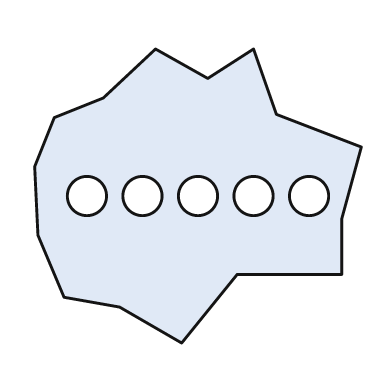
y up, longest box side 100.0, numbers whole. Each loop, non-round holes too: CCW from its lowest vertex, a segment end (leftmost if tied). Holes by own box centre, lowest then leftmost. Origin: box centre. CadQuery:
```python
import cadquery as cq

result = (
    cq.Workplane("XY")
    .moveTo(-5.0, -45.0)
    .lineTo(12.0, -24.0)
    .lineTo(44.0, -24.0)
    .lineTo(44.0, -7.0)
    .lineTo(50.0, 15.0)
    .lineTo(24.0, 25.0)
    .lineTo(17.0, 45.0)
    .lineTo(3.0, 36.0)
    .lineTo(-13.0, 45.0)
    .lineTo(-29.0, 30.0)
    .lineTo(-44.0, 24.0)
    .lineTo(-50.0, 9.0)
    .lineTo(-49.0, -12.0)
    .lineTo(-41.0, -31.0)
    .lineTo(-24.0, -34.0)
    .close()
    .moveTo(-34.0, 0.0)
    .circle(6.0)
    .moveTo(-17.0, 0.0)
    .circle(6.0)
    .moveTo(0.0, 0.0)
    .circle(6.0)
    .moveTo(17.0, 0.0)
    .circle(6.0)
    .moveTo(34.0, 0.0)
    .circle(6.0)
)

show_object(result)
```